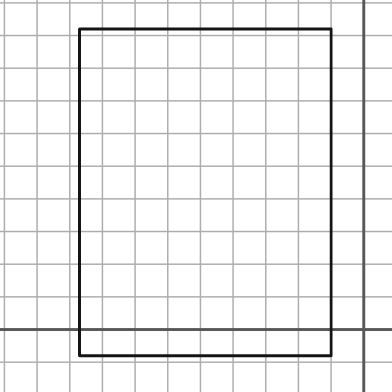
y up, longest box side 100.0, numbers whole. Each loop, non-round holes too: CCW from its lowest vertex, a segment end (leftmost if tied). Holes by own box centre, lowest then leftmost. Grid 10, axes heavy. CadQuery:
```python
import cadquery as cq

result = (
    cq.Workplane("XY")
    .moveTo(-87.0, -8.0)
    .lineTo(-10.0, -8.0)
    .lineTo(-10.0, 92.0)
    .lineTo(-87.0, 92.0)
    .close()
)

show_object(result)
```